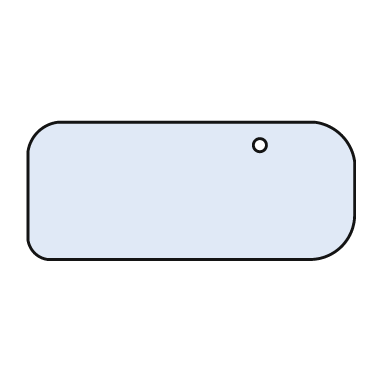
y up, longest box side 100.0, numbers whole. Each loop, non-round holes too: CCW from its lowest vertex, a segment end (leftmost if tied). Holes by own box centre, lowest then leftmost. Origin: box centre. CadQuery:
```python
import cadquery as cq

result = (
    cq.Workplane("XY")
    .moveTo(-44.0, -21.0)
    .lineTo(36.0, -21.0)
    .threePointArc((46.0, -17.0), (50.0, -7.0))
    .lineTo(50.0, 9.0)
    .threePointArc((46.0, 17.0), (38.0, 21.0))
    .lineTo(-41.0, 21.0)
    .threePointArc((-47.0, 18.0), (-50.0, 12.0))
    .lineTo(-50.0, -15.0)
    .threePointArc((-48.0, -19.0), (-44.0, -21.0))
    .close()
    .moveTo(21.0, 14.0)
    .circle(2.0)
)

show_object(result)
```